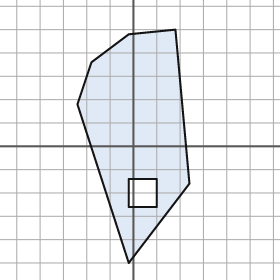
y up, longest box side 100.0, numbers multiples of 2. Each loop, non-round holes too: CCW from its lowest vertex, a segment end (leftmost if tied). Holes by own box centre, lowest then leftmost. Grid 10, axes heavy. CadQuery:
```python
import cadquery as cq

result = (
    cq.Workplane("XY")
    .moveTo(-2.0, -50.0)
    .lineTo(24.0, -16.0)
    .lineTo(18.0, 50.0)
    .lineTo(-2.0, 48.0)
    .lineTo(-18.0, 36.0)
    .lineTo(-24.0, 18.0)
    .close()
    .moveTo(-2.0, -26.0)
    .lineTo(10.0, -26.0)
    .lineTo(10.0, -14.0)
    .lineTo(-2.0, -14.0)
    .close()
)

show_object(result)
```